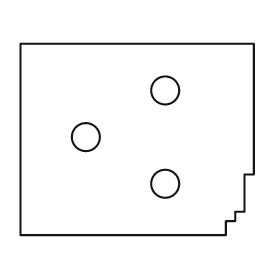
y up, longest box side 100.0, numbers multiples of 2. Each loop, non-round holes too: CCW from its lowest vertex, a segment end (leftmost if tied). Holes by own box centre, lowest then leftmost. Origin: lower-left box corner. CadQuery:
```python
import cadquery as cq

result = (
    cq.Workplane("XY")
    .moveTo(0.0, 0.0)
    .lineTo(88.0, 0.0)
    .lineTo(88.0, 6.0)
    .lineTo(92.0, 6.0)
    .lineTo(92.0, 10.0)
    .lineTo(96.0, 10.0)
    .lineTo(96.0, 26.0)
    .lineTo(100.0, 26.0)
    .lineTo(100.0, 82.0)
    .lineTo(0.0, 82.0)
    .close()
    .moveTo(62.0, 22.0)
    .circle(6.0)
    .moveTo(28.0, 42.0)
    .circle(6.0)
    .moveTo(62.0, 62.0)
    .circle(6.0)
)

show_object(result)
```